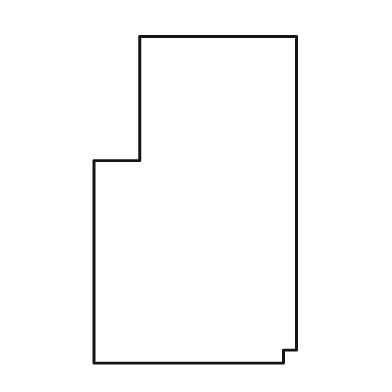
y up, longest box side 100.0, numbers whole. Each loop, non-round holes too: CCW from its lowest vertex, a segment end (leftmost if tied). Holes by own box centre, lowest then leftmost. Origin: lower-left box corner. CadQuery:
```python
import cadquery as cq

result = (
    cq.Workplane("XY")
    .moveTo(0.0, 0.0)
    .lineTo(58.0, 0.0)
    .lineTo(58.0, 4.0)
    .lineTo(62.0, 4.0)
    .lineTo(62.0, 100.0)
    .lineTo(14.0, 100.0)
    .lineTo(14.0, 62.0)
    .lineTo(0.0, 62.0)
    .close()
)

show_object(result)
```